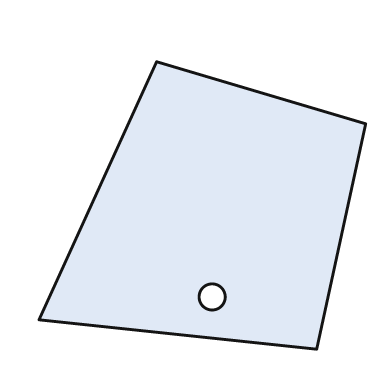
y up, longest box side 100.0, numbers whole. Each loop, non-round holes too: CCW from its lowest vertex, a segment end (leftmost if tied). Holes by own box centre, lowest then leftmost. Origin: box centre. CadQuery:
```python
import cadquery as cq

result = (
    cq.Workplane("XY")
    .moveTo(35.0, -44.0)
    .lineTo(50.0, 25.0)
    .lineTo(-14.0, 44.0)
    .lineTo(-50.0, -35.0)
    .close()
    .moveTo(3.0, -28.0)
    .circle(4.0)
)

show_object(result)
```